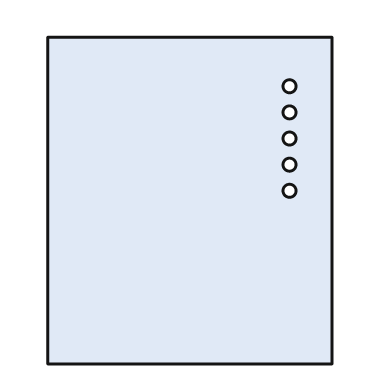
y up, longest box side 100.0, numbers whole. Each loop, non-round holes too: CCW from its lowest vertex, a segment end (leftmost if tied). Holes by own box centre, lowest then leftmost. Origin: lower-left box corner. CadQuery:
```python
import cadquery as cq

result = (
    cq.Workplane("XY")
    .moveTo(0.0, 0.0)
    .lineTo(87.0, 0.0)
    .lineTo(87.0, 100.0)
    .lineTo(0.0, 100.0)
    .close()
    .moveTo(74.0, 53.0)
    .circle(2.0)
    .moveTo(74.0, 61.0)
    .circle(2.0)
    .moveTo(74.0, 69.0)
    .circle(2.0)
    .moveTo(74.0, 77.0)
    .circle(2.0)
    .moveTo(74.0, 85.0)
    .circle(2.0)
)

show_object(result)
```